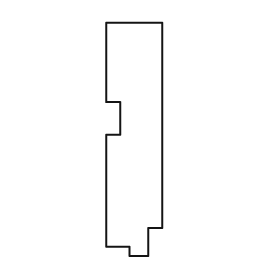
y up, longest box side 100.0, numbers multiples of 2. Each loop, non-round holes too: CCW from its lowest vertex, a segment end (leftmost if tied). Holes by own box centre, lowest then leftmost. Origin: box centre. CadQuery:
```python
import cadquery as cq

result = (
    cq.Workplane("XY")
    .moveTo(-2.0, -50.0)
    .lineTo(6.0, -50.0)
    .lineTo(6.0, -38.0)
    .lineTo(12.0, -38.0)
    .lineTo(12.0, 50.0)
    .lineTo(-12.0, 50.0)
    .lineTo(-12.0, 16.0)
    .lineTo(-6.0, 16.0)
    .lineTo(-6.0, 2.0)
    .lineTo(-12.0, 2.0)
    .lineTo(-12.0, -46.0)
    .lineTo(-2.0, -46.0)
    .close()
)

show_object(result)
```